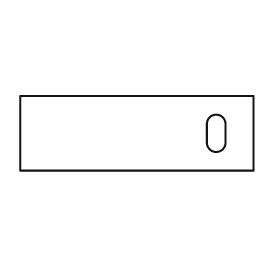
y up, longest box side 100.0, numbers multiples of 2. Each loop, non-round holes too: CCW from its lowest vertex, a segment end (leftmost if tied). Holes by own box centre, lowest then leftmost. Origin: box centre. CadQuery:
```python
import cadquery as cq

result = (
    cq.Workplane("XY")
    .moveTo(-50.0, -16.0)
    .lineTo(50.0, -16.0)
    .lineTo(50.0, 16.0)
    .lineTo(-50.0, 16.0)
    .close()
    .moveTo(30.0, -4.0)
    .threePointArc((34.0, -8.0), (38.0, -4.0))
    .lineTo(38.0, 4.0)
    .threePointArc((34.0, 8.0), (30.0, 4.0))
    .close()
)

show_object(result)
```